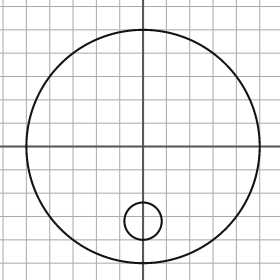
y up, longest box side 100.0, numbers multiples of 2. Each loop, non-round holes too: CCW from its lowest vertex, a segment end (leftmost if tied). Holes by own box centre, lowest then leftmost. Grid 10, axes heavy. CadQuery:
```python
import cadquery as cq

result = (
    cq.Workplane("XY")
    .moveTo(0.0, 0.0)
    .circle(50.0)
    .moveTo(0.0, -32.0)
    .circle(8.0)
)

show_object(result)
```